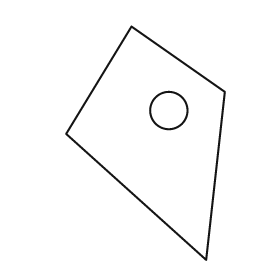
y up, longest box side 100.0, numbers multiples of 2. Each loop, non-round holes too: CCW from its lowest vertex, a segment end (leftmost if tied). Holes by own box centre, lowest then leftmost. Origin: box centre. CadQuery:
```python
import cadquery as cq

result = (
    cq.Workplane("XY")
    .moveTo(26.0, -50.0)
    .lineTo(34.0, 22.0)
    .lineTo(-6.0, 50.0)
    .lineTo(-34.0, 4.0)
    .close()
    .moveTo(10.0, 14.0)
    .circle(8.0)
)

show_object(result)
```